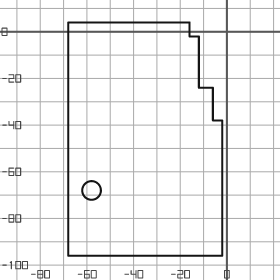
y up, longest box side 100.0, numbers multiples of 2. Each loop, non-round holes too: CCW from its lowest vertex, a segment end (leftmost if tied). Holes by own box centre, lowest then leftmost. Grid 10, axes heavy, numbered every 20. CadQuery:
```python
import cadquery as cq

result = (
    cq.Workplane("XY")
    .moveTo(-68.0, -96.0)
    .lineTo(-2.0, -96.0)
    .lineTo(-2.0, -38.0)
    .lineTo(-6.0, -38.0)
    .lineTo(-6.0, -24.0)
    .lineTo(-12.0, -24.0)
    .lineTo(-12.0, -2.0)
    .lineTo(-16.0, -2.0)
    .lineTo(-16.0, 4.0)
    .lineTo(-68.0, 4.0)
    .close()
    .moveTo(-58.0, -68.0)
    .circle(4.0)
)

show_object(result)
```